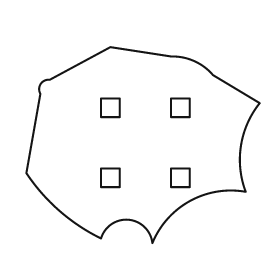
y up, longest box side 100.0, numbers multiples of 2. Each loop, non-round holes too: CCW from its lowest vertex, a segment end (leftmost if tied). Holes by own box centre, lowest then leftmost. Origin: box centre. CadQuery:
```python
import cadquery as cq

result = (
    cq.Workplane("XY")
    .moveTo(4.0, -42.0)
    .threePointArc((20.0, -24.0), (44.0, -20.0))
    .threePointArc((42.0, 0.0), (50.0, 18.0))
    .lineTo(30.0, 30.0)
    .threePointArc((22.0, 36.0), (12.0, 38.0))
    .lineTo(-14.0, 42.0)
    .lineTo(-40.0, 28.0)
    .threePointArc((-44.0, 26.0), (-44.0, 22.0))
    .lineTo(-50.0, -12.0)
    .threePointArc((-36.0, -28.0), (-18.0, -40.0))
    .threePointArc((-6.0, -32.0), (4.0, -42.0))
    .close()
    .moveTo(-18.0, -18.0)
    .lineTo(-10.0, -18.0)
    .lineTo(-10.0, -10.0)
    .lineTo(-18.0, -10.0)
    .close()
    .moveTo(12.0, -18.0)
    .lineTo(20.0, -18.0)
    .lineTo(20.0, -10.0)
    .lineTo(12.0, -10.0)
    .close()
    .moveTo(-18.0, 12.0)
    .lineTo(-10.0, 12.0)
    .lineTo(-10.0, 20.0)
    .lineTo(-18.0, 20.0)
    .close()
    .moveTo(12.0, 12.0)
    .lineTo(20.0, 12.0)
    .lineTo(20.0, 20.0)
    .lineTo(12.0, 20.0)
    .close()
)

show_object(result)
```